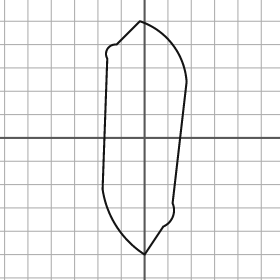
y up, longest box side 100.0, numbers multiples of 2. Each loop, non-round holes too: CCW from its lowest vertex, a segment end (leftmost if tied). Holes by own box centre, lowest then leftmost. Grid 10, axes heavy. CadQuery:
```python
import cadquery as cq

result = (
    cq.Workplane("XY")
    .moveTo(0.0, -50.0)
    .lineTo(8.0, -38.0)
    .threePointArc((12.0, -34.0), (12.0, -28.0))
    .lineTo(18.0, 24.0)
    .threePointArc((12.0, 40.0), (-2.0, 50.0))
    .lineTo(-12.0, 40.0)
    .threePointArc((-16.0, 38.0), (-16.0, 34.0))
    .lineTo(-18.0, -22.0)
    .threePointArc((-12.0, -38.0), (0.0, -50.0))
    .close()
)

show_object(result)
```